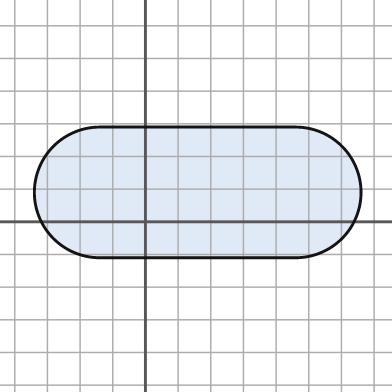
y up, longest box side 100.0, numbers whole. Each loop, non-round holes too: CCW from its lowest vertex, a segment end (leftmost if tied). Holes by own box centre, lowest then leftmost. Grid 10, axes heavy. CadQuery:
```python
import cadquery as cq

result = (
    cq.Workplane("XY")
    .moveTo(-14.0, -11.0)
    .lineTo(46.0, -11.0)
    .threePointArc((66.0, 9.0), (46.0, 29.0))
    .lineTo(-14.0, 29.0)
    .threePointArc((-34.0, 9.0), (-14.0, -11.0))
    .close()
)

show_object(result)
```